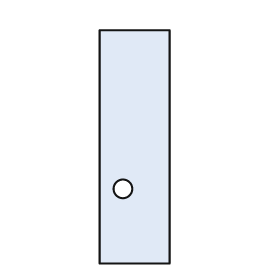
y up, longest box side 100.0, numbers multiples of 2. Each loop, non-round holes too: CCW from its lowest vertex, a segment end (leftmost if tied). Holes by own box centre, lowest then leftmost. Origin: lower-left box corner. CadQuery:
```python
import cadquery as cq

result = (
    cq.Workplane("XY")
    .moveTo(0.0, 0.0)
    .lineTo(30.0, 0.0)
    .lineTo(30.0, 100.0)
    .lineTo(0.0, 100.0)
    .close()
    .moveTo(10.0, 32.0)
    .circle(4.0)
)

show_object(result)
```